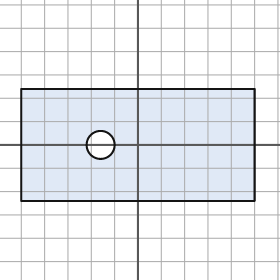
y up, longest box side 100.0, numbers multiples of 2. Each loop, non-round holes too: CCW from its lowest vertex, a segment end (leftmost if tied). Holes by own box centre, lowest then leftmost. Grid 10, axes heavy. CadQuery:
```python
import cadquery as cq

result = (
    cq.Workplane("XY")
    .moveTo(-50.0, -24.0)
    .lineTo(50.0, -24.0)
    .lineTo(50.0, 24.0)
    .lineTo(-50.0, 24.0)
    .close()
    .moveTo(-16.0, 0.0)
    .circle(6.0)
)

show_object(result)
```